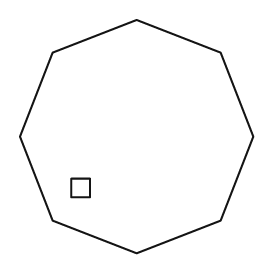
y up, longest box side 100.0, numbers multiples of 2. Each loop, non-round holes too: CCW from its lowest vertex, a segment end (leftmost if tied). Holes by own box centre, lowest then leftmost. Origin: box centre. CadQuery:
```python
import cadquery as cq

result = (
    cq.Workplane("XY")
    .moveTo(0.0, -50.0)
    .lineTo(36.0, -36.0)
    .lineTo(50.0, 0.0)
    .lineTo(36.0, 36.0)
    .lineTo(0.0, 50.0)
    .lineTo(-36.0, 36.0)
    .lineTo(-50.0, 0.0)
    .lineTo(-36.0, -36.0)
    .close()
    .moveTo(-28.0, -26.0)
    .lineTo(-20.0, -26.0)
    .lineTo(-20.0, -18.0)
    .lineTo(-28.0, -18.0)
    .close()
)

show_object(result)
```